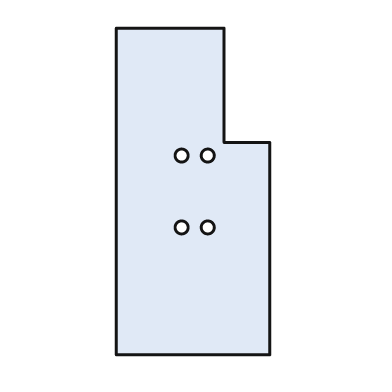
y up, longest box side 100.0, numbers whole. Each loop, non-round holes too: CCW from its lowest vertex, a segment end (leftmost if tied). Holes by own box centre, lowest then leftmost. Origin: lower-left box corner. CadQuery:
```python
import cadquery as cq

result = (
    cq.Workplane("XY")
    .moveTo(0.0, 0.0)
    .lineTo(47.0, 0.0)
    .lineTo(47.0, 65.0)
    .lineTo(33.0, 65.0)
    .lineTo(33.0, 100.0)
    .lineTo(0.0, 100.0)
    .close()
    .moveTo(20.0, 39.0)
    .circle(2.0)
    .moveTo(28.0, 39.0)
    .circle(2.0)
    .moveTo(20.0, 61.0)
    .circle(2.0)
    .moveTo(28.0, 61.0)
    .circle(2.0)
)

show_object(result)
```